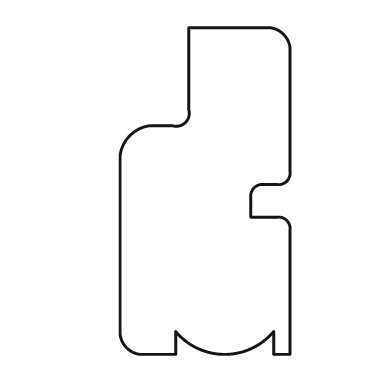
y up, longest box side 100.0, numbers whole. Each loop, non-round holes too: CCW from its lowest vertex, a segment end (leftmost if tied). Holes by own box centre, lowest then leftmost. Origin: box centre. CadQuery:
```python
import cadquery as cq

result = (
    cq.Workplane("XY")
    .moveTo(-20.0, -50.0)
    .lineTo(-9.0, -50.0)
    .lineTo(-9.0, -43.0)
    .threePointArc((6.0, -50.0), (21.0, -43.0))
    .lineTo(21.0, -50.0)
    .lineTo(26.0, -50.0)
    .lineTo(26.0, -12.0)
    .threePointArc((25.0, -9.0), (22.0, -8.0))
    .lineTo(14.0, -8.0)
    .lineTo(14.0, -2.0)
    .threePointArc((15.0, 1.0), (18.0, 2.0))
    .lineTo(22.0, 2.0)
    .threePointArc((25.0, 3.0), (26.0, 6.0))
    .lineTo(26.0, 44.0)
    .threePointArc((24.0, 48.0), (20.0, 50.0))
    .lineTo(-5.0, 50.0)
    .lineTo(-5.0, 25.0)
    .threePointArc((-6.0, 21.0), (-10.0, 20.0))
    .lineTo(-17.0, 20.0)
    .threePointArc((-23.0, 17.0), (-26.0, 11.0))
    .lineTo(-26.0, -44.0)
    .threePointArc((-24.0, -48.0), (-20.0, -50.0))
    .close()
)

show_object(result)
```